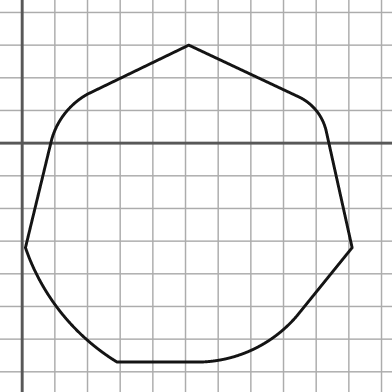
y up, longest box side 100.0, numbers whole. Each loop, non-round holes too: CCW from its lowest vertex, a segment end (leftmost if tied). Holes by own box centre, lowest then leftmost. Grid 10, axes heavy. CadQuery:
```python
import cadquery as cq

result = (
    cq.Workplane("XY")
    .moveTo(29.0, -67.0)
    .lineTo(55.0, -67.0)
    .threePointArc((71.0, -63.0), (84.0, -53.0))
    .lineTo(101.0, -32.0)
    .lineTo(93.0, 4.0)
    .threePointArc((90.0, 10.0), (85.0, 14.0))
    .lineTo(51.0, 30.0)
    .lineTo(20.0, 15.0)
    .threePointArc((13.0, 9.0), (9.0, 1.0))
    .lineTo(1.0, -32.0)
    .threePointArc((12.0, -52.0), (29.0, -67.0))
    .close()
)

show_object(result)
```